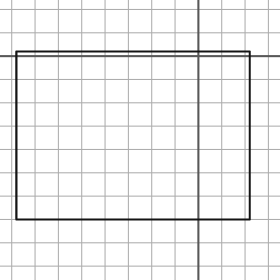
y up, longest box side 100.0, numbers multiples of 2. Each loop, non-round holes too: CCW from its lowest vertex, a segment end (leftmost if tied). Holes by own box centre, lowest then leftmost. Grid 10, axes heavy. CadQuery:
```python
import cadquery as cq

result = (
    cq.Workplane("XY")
    .moveTo(-78.0, -70.0)
    .lineTo(22.0, -70.0)
    .lineTo(22.0, 2.0)
    .lineTo(-78.0, 2.0)
    .close()
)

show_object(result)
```